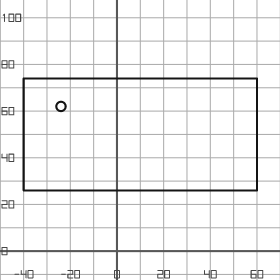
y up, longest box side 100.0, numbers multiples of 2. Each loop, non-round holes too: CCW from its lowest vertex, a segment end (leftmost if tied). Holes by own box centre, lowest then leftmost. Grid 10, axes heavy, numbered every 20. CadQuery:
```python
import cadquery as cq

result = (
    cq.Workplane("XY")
    .moveTo(-40.0, 26.0)
    .lineTo(60.0, 26.0)
    .lineTo(60.0, 74.0)
    .lineTo(-40.0, 74.0)
    .close()
    .moveTo(-24.0, 62.0)
    .circle(2.0)
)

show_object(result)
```